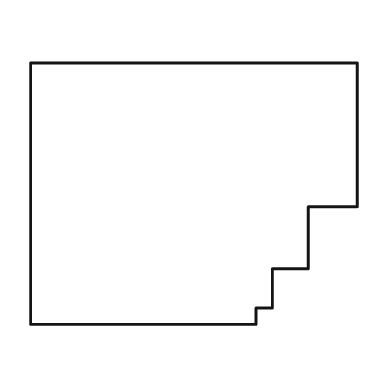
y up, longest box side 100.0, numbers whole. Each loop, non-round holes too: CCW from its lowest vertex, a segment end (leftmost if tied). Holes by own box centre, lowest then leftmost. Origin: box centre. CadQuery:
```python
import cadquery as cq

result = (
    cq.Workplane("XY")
    .moveTo(-50.0, -40.0)
    .lineTo(19.0, -40.0)
    .lineTo(19.0, -35.0)
    .lineTo(24.0, -35.0)
    .lineTo(24.0, -23.0)
    .lineTo(35.0, -23.0)
    .lineTo(35.0, -4.0)
    .lineTo(50.0, -4.0)
    .lineTo(50.0, 40.0)
    .lineTo(-50.0, 40.0)
    .close()
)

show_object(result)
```